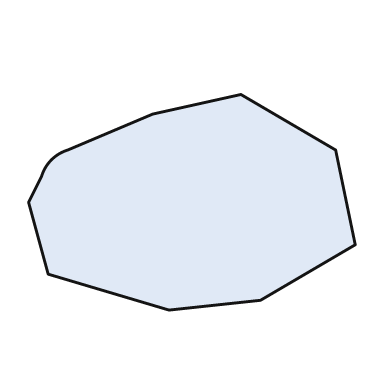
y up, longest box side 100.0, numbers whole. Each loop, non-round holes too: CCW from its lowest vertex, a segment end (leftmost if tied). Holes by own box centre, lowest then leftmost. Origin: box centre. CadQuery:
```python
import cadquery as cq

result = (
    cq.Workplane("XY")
    .moveTo(-7.0, -33.0)
    .lineTo(21.0, -30.0)
    .lineTo(50.0, -13.0)
    .lineTo(44.0, 16.0)
    .lineTo(15.0, 33.0)
    .lineTo(-12.0, 27.0)
    .lineTo(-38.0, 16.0)
    .threePointArc((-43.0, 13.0), (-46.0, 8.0))
    .lineTo(-50.0, 0.0)
    .lineTo(-44.0, -22.0)
    .close()
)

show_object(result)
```